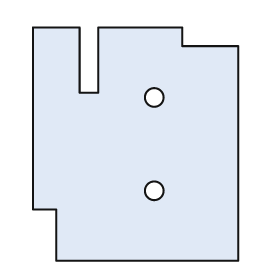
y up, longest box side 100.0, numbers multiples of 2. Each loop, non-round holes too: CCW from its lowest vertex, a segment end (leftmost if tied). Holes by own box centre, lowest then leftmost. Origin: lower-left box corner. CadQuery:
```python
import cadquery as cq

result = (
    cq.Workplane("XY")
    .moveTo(10.0, 0.0)
    .lineTo(88.0, 0.0)
    .lineTo(88.0, 92.0)
    .lineTo(64.0, 92.0)
    .lineTo(64.0, 100.0)
    .lineTo(28.0, 100.0)
    .lineTo(28.0, 72.0)
    .lineTo(20.0, 72.0)
    .lineTo(20.0, 100.0)
    .lineTo(0.0, 100.0)
    .lineTo(0.0, 22.0)
    .lineTo(10.0, 22.0)
    .close()
    .moveTo(52.0, 30.0)
    .circle(4.0)
    .moveTo(52.0, 70.0)
    .circle(4.0)
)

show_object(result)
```